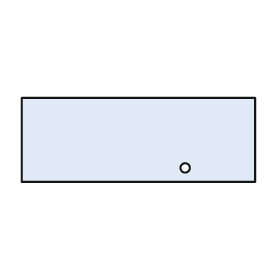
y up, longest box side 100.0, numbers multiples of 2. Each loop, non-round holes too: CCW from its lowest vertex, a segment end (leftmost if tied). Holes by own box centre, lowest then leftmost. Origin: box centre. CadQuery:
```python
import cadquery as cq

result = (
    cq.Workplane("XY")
    .moveTo(-50.0, -18.0)
    .lineTo(50.0, -18.0)
    .lineTo(50.0, 18.0)
    .lineTo(-50.0, 18.0)
    .close()
    .moveTo(20.0, -12.0)
    .circle(2.0)
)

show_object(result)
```